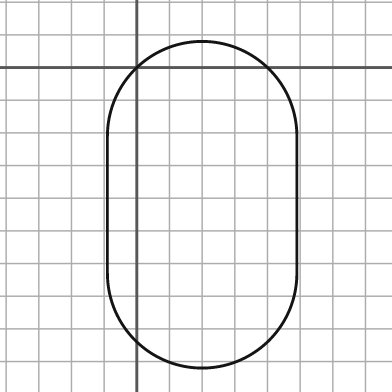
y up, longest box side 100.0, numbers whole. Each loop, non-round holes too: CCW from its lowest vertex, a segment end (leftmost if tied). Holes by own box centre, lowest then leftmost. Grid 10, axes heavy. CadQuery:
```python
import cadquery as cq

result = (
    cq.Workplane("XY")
    .moveTo(-9.0, -63.0)
    .threePointArc((20.0, -92.0), (49.0, -63.0))
    .lineTo(49.0, -21.0)
    .threePointArc((20.0, 8.0), (-9.0, -21.0))
    .close()
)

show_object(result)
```